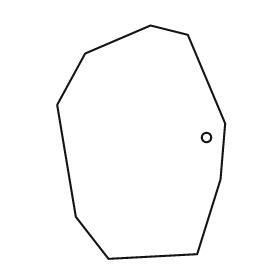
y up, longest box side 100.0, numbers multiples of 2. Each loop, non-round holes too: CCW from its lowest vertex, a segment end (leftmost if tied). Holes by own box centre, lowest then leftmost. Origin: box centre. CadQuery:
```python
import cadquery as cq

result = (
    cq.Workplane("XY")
    .moveTo(-14.0, -50.0)
    .lineTo(24.0, -48.0)
    .lineTo(34.0, -16.0)
    .lineTo(36.0, 8.0)
    .lineTo(20.0, 46.0)
    .lineTo(4.0, 50.0)
    .lineTo(-24.0, 38.0)
    .lineTo(-36.0, 16.0)
    .lineTo(-28.0, -32.0)
    .close()
    .moveTo(28.0, 2.0)
    .circle(2.0)
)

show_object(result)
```